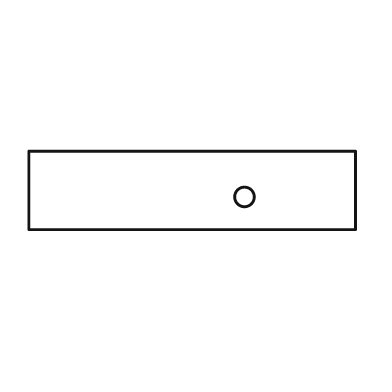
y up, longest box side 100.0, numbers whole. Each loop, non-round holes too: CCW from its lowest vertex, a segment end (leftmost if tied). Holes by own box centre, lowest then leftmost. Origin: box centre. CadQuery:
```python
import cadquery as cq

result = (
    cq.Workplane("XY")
    .moveTo(-50.0, -12.0)
    .lineTo(50.0, -12.0)
    .lineTo(50.0, 12.0)
    .lineTo(-50.0, 12.0)
    .close()
    .moveTo(16.0, -2.0)
    .circle(3.0)
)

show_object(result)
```